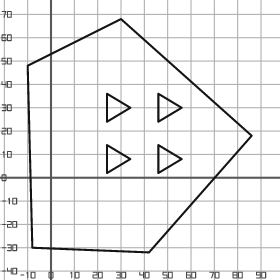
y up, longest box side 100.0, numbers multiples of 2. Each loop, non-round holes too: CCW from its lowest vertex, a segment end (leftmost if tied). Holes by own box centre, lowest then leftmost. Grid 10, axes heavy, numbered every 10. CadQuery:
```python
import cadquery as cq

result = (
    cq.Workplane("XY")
    .moveTo(42.0, -32.0)
    .lineTo(86.0, 18.0)
    .lineTo(30.0, 68.0)
    .lineTo(-10.0, 48.0)
    .lineTo(-8.0, -30.0)
    .close()
    .moveTo(24.0, 2.0)
    .lineTo(34.0, 8.0)
    .lineTo(24.0, 14.0)
    .close()
    .moveTo(46.0, 2.0)
    .lineTo(56.0, 8.0)
    .lineTo(46.0, 14.0)
    .close()
    .moveTo(24.0, 24.0)
    .lineTo(34.0, 30.0)
    .lineTo(24.0, 36.0)
    .close()
    .moveTo(46.0, 24.0)
    .lineTo(56.0, 30.0)
    .lineTo(46.0, 36.0)
    .close()
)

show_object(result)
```